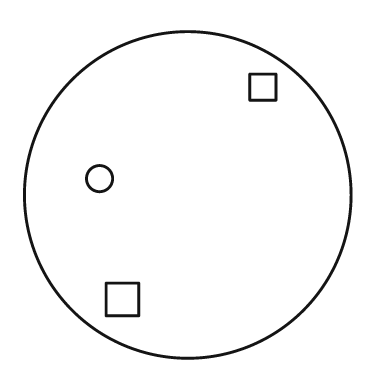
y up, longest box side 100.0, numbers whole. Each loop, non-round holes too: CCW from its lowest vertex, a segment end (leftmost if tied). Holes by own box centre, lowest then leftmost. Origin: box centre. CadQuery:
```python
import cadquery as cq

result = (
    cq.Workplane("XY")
    .moveTo(0.0, 0.0)
    .circle(50.0)
    .moveTo(-25.0, -37.0)
    .lineTo(-15.0, -37.0)
    .lineTo(-15.0, -27.0)
    .lineTo(-25.0, -27.0)
    .close()
    .moveTo(-27.0, 5.0)
    .circle(4.0)
    .moveTo(19.0, 29.0)
    .lineTo(27.0, 29.0)
    .lineTo(27.0, 37.0)
    .lineTo(19.0, 37.0)
    .close()
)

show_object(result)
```